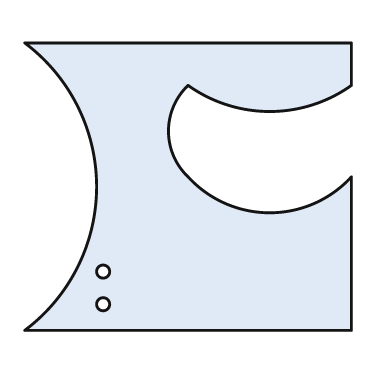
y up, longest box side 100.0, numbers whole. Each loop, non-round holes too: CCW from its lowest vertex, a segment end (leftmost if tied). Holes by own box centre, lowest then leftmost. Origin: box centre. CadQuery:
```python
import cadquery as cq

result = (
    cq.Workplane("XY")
    .moveTo(-50.0, -44.0)
    .lineTo(50.0, -44.0)
    .lineTo(50.0, 3.0)
    .threePointArc((25.0, -8.0), (0.0, 3.0))
    .threePointArc((-6.0, 17.0), (0.0, 31.0))
    .threePointArc((25.0, 23.0), (50.0, 31.0))
    .lineTo(50.0, 44.0)
    .lineTo(-50.0, 44.0)
    .threePointArc((-28.0, 0.0), (-50.0, -44.0))
    .close()
    .moveTo(-26.0, -36.0)
    .circle(2.0)
    .moveTo(-26.0, -26.0)
    .circle(2.0)
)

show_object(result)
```